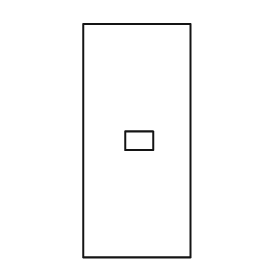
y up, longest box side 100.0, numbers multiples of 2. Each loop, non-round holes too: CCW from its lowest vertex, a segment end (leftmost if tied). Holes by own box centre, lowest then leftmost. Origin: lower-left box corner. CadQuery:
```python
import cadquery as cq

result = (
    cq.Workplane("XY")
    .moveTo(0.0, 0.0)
    .lineTo(46.0, 0.0)
    .lineTo(46.0, 100.0)
    .lineTo(0.0, 100.0)
    .close()
    .moveTo(18.0, 46.0)
    .lineTo(30.0, 46.0)
    .lineTo(30.0, 54.0)
    .lineTo(18.0, 54.0)
    .close()
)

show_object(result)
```